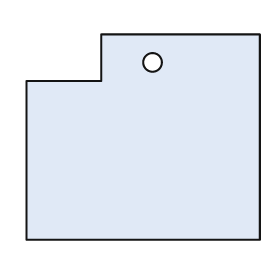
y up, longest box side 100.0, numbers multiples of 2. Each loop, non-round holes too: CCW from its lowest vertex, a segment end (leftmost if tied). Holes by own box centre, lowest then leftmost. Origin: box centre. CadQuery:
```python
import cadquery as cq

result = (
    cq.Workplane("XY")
    .moveTo(-50.0, -44.0)
    .lineTo(50.0, -44.0)
    .lineTo(50.0, 44.0)
    .lineTo(-18.0, 44.0)
    .lineTo(-18.0, 24.0)
    .lineTo(-50.0, 24.0)
    .close()
    .moveTo(4.0, 32.0)
    .circle(4.0)
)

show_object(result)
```